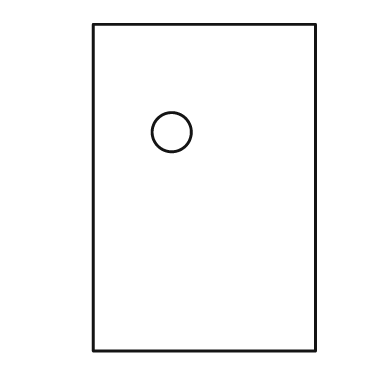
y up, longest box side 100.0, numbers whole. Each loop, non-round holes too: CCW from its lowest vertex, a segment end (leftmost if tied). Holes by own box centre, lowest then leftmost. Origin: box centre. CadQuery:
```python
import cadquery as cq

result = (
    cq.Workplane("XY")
    .moveTo(-34.0, -50.0)
    .lineTo(34.0, -50.0)
    .lineTo(34.0, 50.0)
    .lineTo(-34.0, 50.0)
    .close()
    .moveTo(-10.0, 17.0)
    .circle(6.0)
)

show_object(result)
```